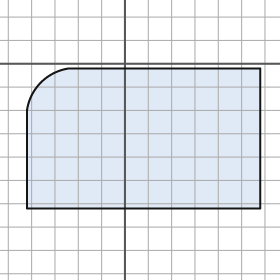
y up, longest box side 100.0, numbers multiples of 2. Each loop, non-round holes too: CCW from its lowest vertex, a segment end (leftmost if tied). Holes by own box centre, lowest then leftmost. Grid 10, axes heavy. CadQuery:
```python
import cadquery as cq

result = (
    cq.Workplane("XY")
    .moveTo(-42.0, -62.0)
    .lineTo(58.0, -62.0)
    .lineTo(58.0, -2.0)
    .lineTo(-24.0, -2.0)
    .threePointArc((-36.0, -8.0), (-42.0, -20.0))
    .close()
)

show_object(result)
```